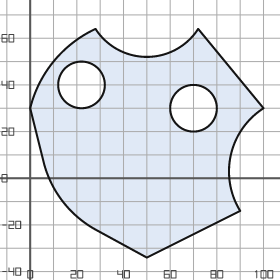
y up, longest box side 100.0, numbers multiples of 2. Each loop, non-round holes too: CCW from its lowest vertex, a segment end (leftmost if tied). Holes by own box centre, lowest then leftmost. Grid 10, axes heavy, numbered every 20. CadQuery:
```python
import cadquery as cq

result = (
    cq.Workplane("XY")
    .moveTo(50.0, -34.0)
    .lineTo(90.0, -14.0)
    .threePointArc((86.0, 10.0), (100.0, 30.0))
    .lineTo(72.0, 64.0)
    .threePointArc((50.0, 52.0), (28.0, 64.0))
    .threePointArc((10.0, 50.0), (0.0, 30.0))
    .lineTo(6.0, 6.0)
    .threePointArc((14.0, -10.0), (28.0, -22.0))
    .close()
    .moveTo(70.0, 30.0)
    .circle(10.0)
    .moveTo(22.0, 40.0)
    .circle(10.0)
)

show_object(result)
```